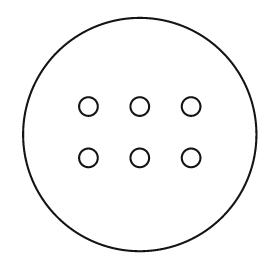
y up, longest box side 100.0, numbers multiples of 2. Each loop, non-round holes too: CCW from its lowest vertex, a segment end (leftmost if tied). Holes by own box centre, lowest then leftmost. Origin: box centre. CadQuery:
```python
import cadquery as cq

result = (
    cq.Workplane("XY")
    .moveTo(0.0, 0.0)
    .circle(50.0)
    .moveTo(-22.0, -10.0)
    .circle(4.0)
    .moveTo(0.0, -10.0)
    .circle(4.0)
    .moveTo(22.0, -10.0)
    .circle(4.0)
    .moveTo(-22.0, 12.0)
    .circle(4.0)
    .moveTo(0.0, 12.0)
    .circle(4.0)
    .moveTo(22.0, 12.0)
    .circle(4.0)
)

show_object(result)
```